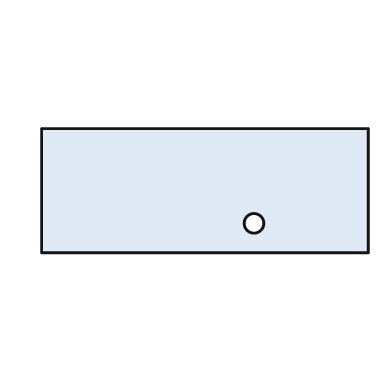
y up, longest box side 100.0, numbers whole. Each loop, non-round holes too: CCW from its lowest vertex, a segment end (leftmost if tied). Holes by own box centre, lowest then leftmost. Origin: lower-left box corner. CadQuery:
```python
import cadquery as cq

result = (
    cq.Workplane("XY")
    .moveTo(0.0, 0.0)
    .lineTo(100.0, 0.0)
    .lineTo(100.0, 38.0)
    .lineTo(0.0, 38.0)
    .close()
    .moveTo(65.0, 9.0)
    .circle(3.0)
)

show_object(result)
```